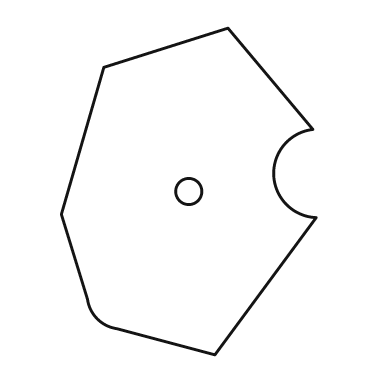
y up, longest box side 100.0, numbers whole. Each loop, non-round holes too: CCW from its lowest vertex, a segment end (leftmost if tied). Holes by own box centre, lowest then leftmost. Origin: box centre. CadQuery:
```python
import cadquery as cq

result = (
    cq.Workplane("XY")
    .moveTo(8.0, -50.0)
    .lineTo(39.0, -8.0)
    .threePointArc((26.0, 5.0), (38.0, 19.0))
    .lineTo(12.0, 50.0)
    .lineTo(-26.0, 38.0)
    .lineTo(-39.0, -7.0)
    .lineTo(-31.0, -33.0)
    .threePointArc((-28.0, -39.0), (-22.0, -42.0))
    .close()
    .moveTo(0.0, 0.0)
    .circle(4.0)
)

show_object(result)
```